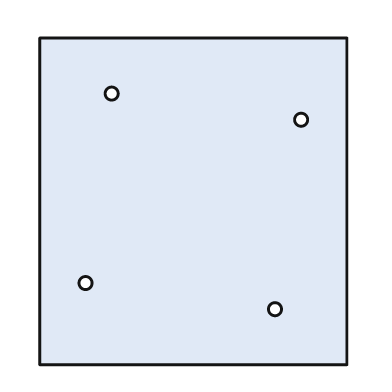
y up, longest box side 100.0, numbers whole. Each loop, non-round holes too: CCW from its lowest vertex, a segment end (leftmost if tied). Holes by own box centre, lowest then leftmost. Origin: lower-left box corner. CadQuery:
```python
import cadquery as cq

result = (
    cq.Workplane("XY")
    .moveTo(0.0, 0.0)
    .lineTo(94.0, 0.0)
    .lineTo(94.0, 100.0)
    .lineTo(0.0, 100.0)
    .close()
    .moveTo(72.0, 17.0)
    .circle(2.0)
    .moveTo(14.0, 25.0)
    .circle(2.0)
    .moveTo(80.0, 75.0)
    .circle(2.0)
    .moveTo(22.0, 83.0)
    .circle(2.0)
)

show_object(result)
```